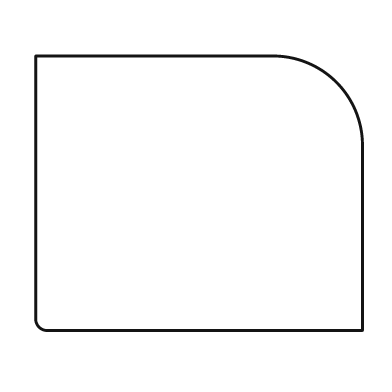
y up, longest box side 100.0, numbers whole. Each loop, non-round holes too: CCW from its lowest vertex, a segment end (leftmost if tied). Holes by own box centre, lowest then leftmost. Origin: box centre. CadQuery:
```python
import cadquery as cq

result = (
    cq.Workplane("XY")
    .moveTo(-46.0, -42.0)
    .lineTo(50.0, -42.0)
    .lineTo(50.0, 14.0)
    .threePointArc((42.0, 34.0), (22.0, 42.0))
    .lineTo(-50.0, 42.0)
    .lineTo(-50.0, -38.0)
    .threePointArc((-49.0, -41.0), (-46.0, -42.0))
    .close()
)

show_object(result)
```